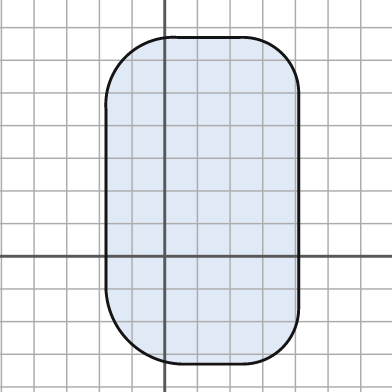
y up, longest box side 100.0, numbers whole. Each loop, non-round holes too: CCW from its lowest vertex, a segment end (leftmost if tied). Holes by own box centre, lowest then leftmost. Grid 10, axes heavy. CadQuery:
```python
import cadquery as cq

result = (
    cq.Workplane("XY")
    .moveTo(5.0, -33.0)
    .lineTo(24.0, -33.0)
    .threePointArc((36.0, -28.0), (41.0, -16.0))
    .lineTo(41.0, 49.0)
    .threePointArc((36.0, 62.0), (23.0, 67.0))
    .lineTo(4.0, 67.0)
    .threePointArc((-12.0, 61.0), (-18.0, 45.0))
    .lineTo(-18.0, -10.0)
    .threePointArc((-11.0, -26.0), (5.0, -33.0))
    .close()
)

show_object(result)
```